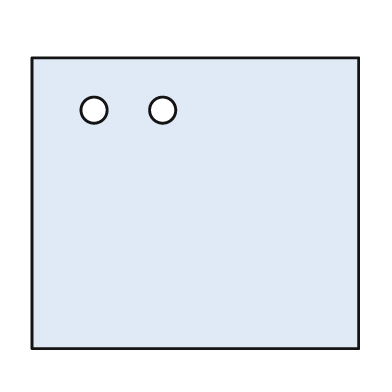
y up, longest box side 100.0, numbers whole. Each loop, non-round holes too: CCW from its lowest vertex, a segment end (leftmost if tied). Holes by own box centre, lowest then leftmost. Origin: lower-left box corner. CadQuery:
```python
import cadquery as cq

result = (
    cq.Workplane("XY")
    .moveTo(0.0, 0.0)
    .lineTo(100.0, 0.0)
    .lineTo(100.0, 89.0)
    .lineTo(0.0, 89.0)
    .close()
    .moveTo(19.0, 73.0)
    .circle(4.0)
    .moveTo(40.0, 73.0)
    .circle(4.0)
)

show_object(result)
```